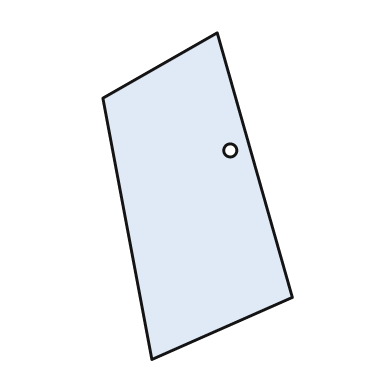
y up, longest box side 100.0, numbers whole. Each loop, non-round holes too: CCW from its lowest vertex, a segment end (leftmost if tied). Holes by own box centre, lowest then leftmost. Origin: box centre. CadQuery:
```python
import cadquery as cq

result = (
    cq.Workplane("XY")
    .moveTo(-14.0, -50.0)
    .lineTo(29.0, -31.0)
    .lineTo(6.0, 50.0)
    .lineTo(-29.0, 30.0)
    .close()
    .moveTo(10.0, 14.0)
    .circle(2.0)
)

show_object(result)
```